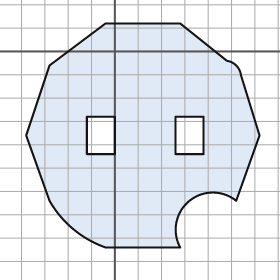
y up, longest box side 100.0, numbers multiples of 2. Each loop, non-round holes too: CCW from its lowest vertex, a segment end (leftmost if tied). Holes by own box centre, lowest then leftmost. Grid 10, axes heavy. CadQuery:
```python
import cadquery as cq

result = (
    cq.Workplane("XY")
    .moveTo(-4.0, -84.0)
    .lineTo(28.0, -84.0)
    .threePointArc((32.0, -64.0), (52.0, -64.0))
    .lineTo(62.0, -36.0)
    .lineTo(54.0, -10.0)
    .threePointArc((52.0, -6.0), (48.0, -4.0))
    .lineTo(28.0, 12.0)
    .lineTo(-4.0, 12.0)
    .lineTo(-28.0, -6.0)
    .lineTo(-38.0, -36.0)
    .lineTo(-28.0, -64.0)
    .threePointArc((-18.0, -76.0), (-4.0, -84.0))
    .close()
    .moveTo(-12.0, -44.0)
    .lineTo(0.0, -44.0)
    .lineTo(0.0, -28.0)
    .lineTo(-12.0, -28.0)
    .close()
    .moveTo(26.0, -44.0)
    .lineTo(38.0, -44.0)
    .lineTo(38.0, -28.0)
    .lineTo(26.0, -28.0)
    .close()
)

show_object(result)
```